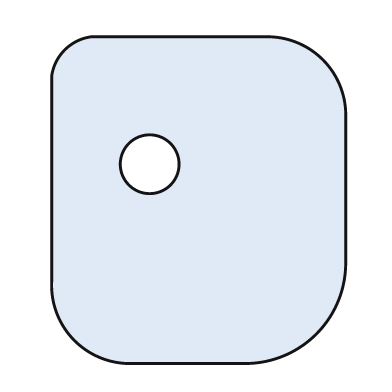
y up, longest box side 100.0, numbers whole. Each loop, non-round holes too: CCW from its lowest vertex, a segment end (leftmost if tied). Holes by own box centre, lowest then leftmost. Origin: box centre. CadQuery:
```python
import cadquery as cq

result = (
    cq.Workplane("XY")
    .moveTo(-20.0, -50.0)
    .lineTo(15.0, -50.0)
    .threePointArc((36.0, -41.0), (45.0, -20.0))
    .lineTo(45.0, 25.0)
    .threePointArc((38.0, 43.0), (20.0, 50.0))
    .lineTo(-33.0, 50.0)
    .threePointArc((-41.0, 46.0), (-45.0, 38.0))
    .lineTo(-45.0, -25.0)
    .threePointArc((-38.0, -43.0), (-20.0, -50.0))
    .close()
    .moveTo(-15.0, 11.0)
    .circle(9.0)
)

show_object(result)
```